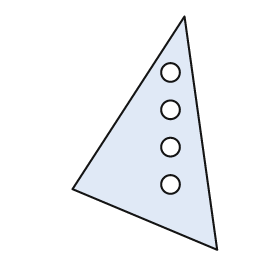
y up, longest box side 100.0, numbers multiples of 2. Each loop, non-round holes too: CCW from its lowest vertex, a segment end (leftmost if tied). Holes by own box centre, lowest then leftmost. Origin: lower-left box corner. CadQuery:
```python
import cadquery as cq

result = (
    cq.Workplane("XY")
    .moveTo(62.0, 0.0)
    .lineTo(48.0, 100.0)
    .lineTo(0.0, 26.0)
    .close()
    .moveTo(42.0, 28.0)
    .circle(4.0)
    .moveTo(42.0, 44.0)
    .circle(4.0)
    .moveTo(42.0, 60.0)
    .circle(4.0)
    .moveTo(42.0, 76.0)
    .circle(4.0)
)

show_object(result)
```